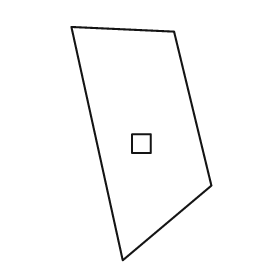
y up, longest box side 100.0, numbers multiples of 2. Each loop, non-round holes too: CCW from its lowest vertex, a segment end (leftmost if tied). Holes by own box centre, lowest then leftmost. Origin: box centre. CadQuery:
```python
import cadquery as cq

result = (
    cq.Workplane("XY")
    .moveTo(-8.0, -50.0)
    .lineTo(30.0, -18.0)
    .lineTo(14.0, 48.0)
    .lineTo(-30.0, 50.0)
    .close()
    .moveTo(-4.0, -4.0)
    .lineTo(4.0, -4.0)
    .lineTo(4.0, 4.0)
    .lineTo(-4.0, 4.0)
    .close()
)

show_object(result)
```